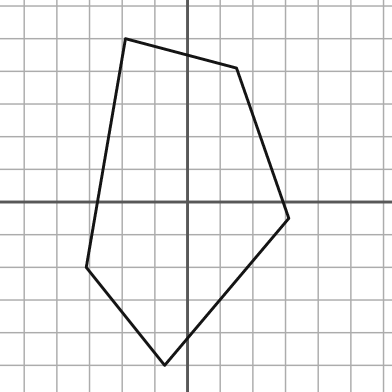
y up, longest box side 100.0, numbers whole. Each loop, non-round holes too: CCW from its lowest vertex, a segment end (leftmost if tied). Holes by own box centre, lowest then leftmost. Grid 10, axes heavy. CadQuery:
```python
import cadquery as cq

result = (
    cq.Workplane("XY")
    .moveTo(-7.0, -50.0)
    .lineTo(31.0, -5.0)
    .lineTo(15.0, 41.0)
    .lineTo(-19.0, 50.0)
    .lineTo(-31.0, -20.0)
    .close()
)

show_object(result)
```